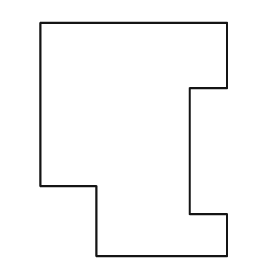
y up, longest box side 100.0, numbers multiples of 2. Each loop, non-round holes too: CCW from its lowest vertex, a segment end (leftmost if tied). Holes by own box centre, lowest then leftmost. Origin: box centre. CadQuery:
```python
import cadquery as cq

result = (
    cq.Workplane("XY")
    .moveTo(-16.0, -50.0)
    .lineTo(40.0, -50.0)
    .lineTo(40.0, -32.0)
    .lineTo(24.0, -32.0)
    .lineTo(24.0, 22.0)
    .lineTo(40.0, 22.0)
    .lineTo(40.0, 50.0)
    .lineTo(-40.0, 50.0)
    .lineTo(-40.0, -20.0)
    .lineTo(-16.0, -20.0)
    .close()
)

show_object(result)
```